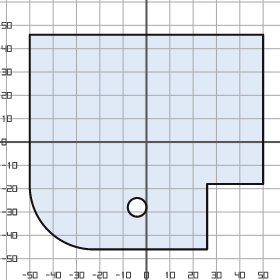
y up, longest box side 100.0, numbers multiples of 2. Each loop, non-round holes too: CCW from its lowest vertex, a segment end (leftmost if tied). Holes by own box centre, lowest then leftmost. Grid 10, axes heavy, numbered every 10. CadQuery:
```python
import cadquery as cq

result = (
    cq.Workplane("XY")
    .moveTo(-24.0, -46.0)
    .lineTo(26.0, -46.0)
    .lineTo(26.0, -18.0)
    .lineTo(50.0, -18.0)
    .lineTo(50.0, 46.0)
    .lineTo(-50.0, 46.0)
    .lineTo(-50.0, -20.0)
    .threePointArc((-42.0, -38.0), (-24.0, -46.0))
    .close()
    .moveTo(-4.0, -28.0)
    .circle(4.0)
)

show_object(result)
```